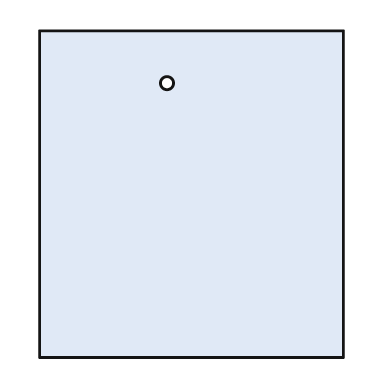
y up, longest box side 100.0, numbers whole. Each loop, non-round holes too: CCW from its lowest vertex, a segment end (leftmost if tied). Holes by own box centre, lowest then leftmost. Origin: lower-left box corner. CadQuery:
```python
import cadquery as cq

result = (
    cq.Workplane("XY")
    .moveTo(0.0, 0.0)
    .lineTo(93.0, 0.0)
    .lineTo(93.0, 100.0)
    .lineTo(0.0, 100.0)
    .close()
    .moveTo(39.0, 84.0)
    .circle(2.0)
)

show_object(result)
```